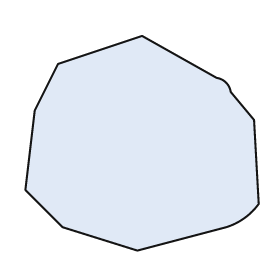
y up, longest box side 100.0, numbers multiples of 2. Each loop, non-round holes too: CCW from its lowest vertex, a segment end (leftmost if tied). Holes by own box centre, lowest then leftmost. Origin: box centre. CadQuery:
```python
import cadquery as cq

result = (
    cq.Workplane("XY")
    .moveTo(-2.0, -46.0)
    .lineTo(36.0, -36.0)
    .threePointArc((44.0, -32.0), (50.0, -26.0))
    .lineTo(48.0, 10.0)
    .lineTo(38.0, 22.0)
    .threePointArc((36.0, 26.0), (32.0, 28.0))
    .lineTo(0.0, 46.0)
    .lineTo(-36.0, 34.0)
    .lineTo(-46.0, 14.0)
    .lineTo(-50.0, -20.0)
    .lineTo(-34.0, -36.0)
    .close()
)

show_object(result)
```